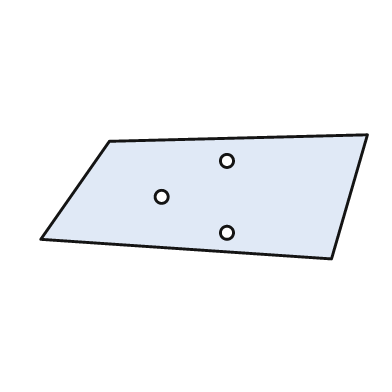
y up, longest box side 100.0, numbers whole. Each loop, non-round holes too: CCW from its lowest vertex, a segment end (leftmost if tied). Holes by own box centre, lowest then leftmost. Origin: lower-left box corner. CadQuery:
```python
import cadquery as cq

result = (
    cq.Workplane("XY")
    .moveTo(89.0, 0.0)
    .lineTo(100.0, 38.0)
    .lineTo(21.0, 36.0)
    .lineTo(0.0, 6.0)
    .close()
    .moveTo(57.0, 8.0)
    .circle(2.0)
    .moveTo(37.0, 19.0)
    .circle(2.0)
    .moveTo(57.0, 30.0)
    .circle(2.0)
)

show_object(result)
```